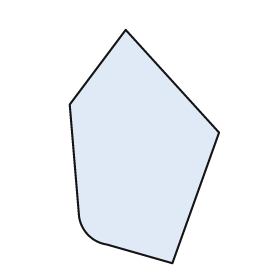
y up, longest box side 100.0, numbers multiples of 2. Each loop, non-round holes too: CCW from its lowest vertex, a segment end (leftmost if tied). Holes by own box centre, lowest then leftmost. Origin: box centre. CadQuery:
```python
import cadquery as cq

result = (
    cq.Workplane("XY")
    .moveTo(12.0, -50.0)
    .lineTo(32.0, 6.0)
    .lineTo(-8.0, 50.0)
    .lineTo(-32.0, 18.0)
    .lineTo(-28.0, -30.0)
    .threePointArc((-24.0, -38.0), (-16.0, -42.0))
    .close()
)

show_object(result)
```